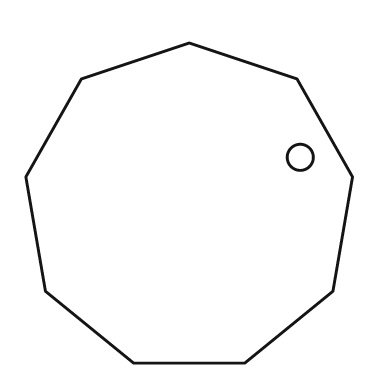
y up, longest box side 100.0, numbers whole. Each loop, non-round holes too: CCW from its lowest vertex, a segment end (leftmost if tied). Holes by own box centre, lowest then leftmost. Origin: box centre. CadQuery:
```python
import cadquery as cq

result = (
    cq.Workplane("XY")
    .moveTo(-17.0, -49.0)
    .lineTo(17.0, -49.0)
    .lineTo(44.0, -27.0)
    .lineTo(50.0, 8.0)
    .lineTo(33.0, 38.0)
    .lineTo(0.0, 49.0)
    .lineTo(-33.0, 38.0)
    .lineTo(-50.0, 8.0)
    .lineTo(-44.0, -27.0)
    .close()
    .moveTo(34.0, 14.0)
    .circle(4.0)
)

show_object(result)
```